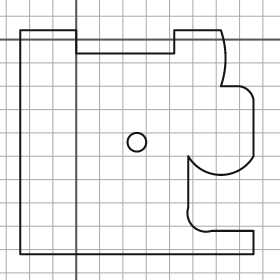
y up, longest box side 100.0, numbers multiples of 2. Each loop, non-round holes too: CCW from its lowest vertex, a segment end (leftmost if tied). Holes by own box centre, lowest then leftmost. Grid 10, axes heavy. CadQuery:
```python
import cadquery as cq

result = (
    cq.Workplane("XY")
    .moveTo(-24.0, -92.0)
    .lineTo(76.0, -92.0)
    .lineTo(76.0, -82.0)
    .lineTo(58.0, -82.0)
    .threePointArc((50.0, -80.0), (48.0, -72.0))
    .lineTo(48.0, -50.0)
    .threePointArc((62.0, -58.0), (76.0, -50.0))
    .lineTo(76.0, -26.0)
    .threePointArc((74.0, -22.0), (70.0, -20.0))
    .lineTo(62.0, -20.0)
    .threePointArc((64.0, -8.0), (62.0, 4.0))
    .lineTo(42.0, 4.0)
    .lineTo(42.0, -6.0)
    .lineTo(0.0, -6.0)
    .lineTo(0.0, 4.0)
    .lineTo(-24.0, 4.0)
    .close()
    .moveTo(26.0, -44.0)
    .circle(4.0)
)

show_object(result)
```